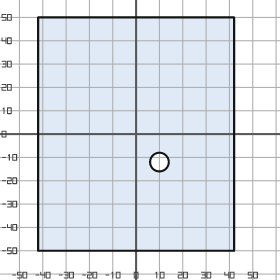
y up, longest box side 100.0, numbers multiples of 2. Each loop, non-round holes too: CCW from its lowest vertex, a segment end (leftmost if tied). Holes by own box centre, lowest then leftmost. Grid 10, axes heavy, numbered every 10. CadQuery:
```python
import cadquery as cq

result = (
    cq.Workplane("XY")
    .moveTo(-42.0, -50.0)
    .lineTo(42.0, -50.0)
    .lineTo(42.0, 50.0)
    .lineTo(-42.0, 50.0)
    .close()
    .moveTo(10.0, -12.0)
    .circle(4.0)
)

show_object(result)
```